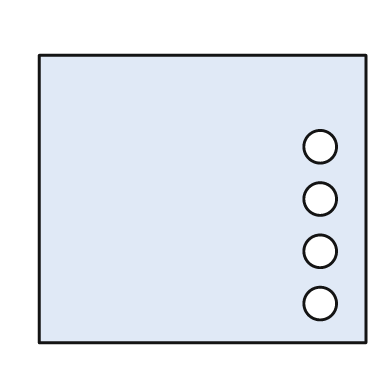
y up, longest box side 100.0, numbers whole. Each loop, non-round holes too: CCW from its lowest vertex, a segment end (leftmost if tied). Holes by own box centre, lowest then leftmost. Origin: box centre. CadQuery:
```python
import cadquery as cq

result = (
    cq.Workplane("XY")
    .moveTo(-50.0, -44.0)
    .lineTo(50.0, -44.0)
    .lineTo(50.0, 44.0)
    .lineTo(-50.0, 44.0)
    .close()
    .moveTo(36.0, -32.0)
    .circle(5.0)
    .moveTo(36.0, -16.0)
    .circle(5.0)
    .moveTo(36.0, 0.0)
    .circle(5.0)
    .moveTo(36.0, 16.0)
    .circle(5.0)
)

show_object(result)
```